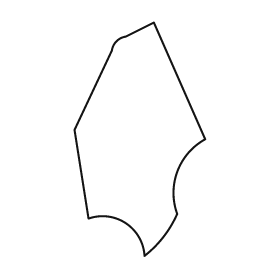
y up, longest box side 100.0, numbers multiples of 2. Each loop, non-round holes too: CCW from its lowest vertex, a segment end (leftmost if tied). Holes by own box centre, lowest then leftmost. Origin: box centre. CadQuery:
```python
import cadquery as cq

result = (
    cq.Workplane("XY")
    .moveTo(2.0, -50.0)
    .threePointArc((10.0, -42.0), (16.0, -32.0))
    .threePointArc((16.0, -14.0), (28.0, 0.0))
    .lineTo(6.0, 50.0)
    .lineTo(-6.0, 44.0)
    .threePointArc((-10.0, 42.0), (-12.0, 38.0))
    .lineTo(-28.0, 4.0)
    .lineTo(-22.0, -34.0)
    .threePointArc((-6.0, -36.0), (2.0, -50.0))
    .close()
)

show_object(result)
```